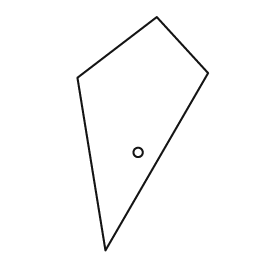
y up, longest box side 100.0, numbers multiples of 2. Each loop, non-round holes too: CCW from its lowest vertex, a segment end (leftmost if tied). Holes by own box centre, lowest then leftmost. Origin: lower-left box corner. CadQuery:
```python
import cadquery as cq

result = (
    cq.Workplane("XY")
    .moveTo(12.0, 0.0)
    .lineTo(56.0, 76.0)
    .lineTo(34.0, 100.0)
    .lineTo(0.0, 74.0)
    .close()
    .moveTo(26.0, 42.0)
    .circle(2.0)
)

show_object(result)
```